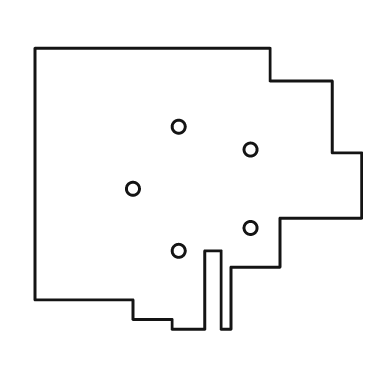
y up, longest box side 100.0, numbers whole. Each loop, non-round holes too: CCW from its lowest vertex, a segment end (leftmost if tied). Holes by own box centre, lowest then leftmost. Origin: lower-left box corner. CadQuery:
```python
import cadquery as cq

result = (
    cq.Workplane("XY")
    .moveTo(42.0, 0.0)
    .lineTo(52.0, 0.0)
    .lineTo(52.0, 24.0)
    .lineTo(57.0, 24.0)
    .lineTo(57.0, 0.0)
    .lineTo(60.0, 0.0)
    .lineTo(60.0, 19.0)
    .lineTo(75.0, 19.0)
    .lineTo(75.0, 34.0)
    .lineTo(100.0, 34.0)
    .lineTo(100.0, 54.0)
    .lineTo(91.0, 54.0)
    .lineTo(91.0, 76.0)
    .lineTo(72.0, 76.0)
    .lineTo(72.0, 86.0)
    .lineTo(0.0, 86.0)
    .lineTo(0.0, 9.0)
    .lineTo(30.0, 9.0)
    .lineTo(30.0, 3.0)
    .lineTo(42.0, 3.0)
    .close()
    .moveTo(44.0, 24.0)
    .circle(2.0)
    .moveTo(66.0, 31.0)
    .circle(2.0)
    .moveTo(30.0, 43.0)
    .circle(2.0)
    .moveTo(66.0, 55.0)
    .circle(2.0)
    .moveTo(44.0, 62.0)
    .circle(2.0)
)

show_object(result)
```